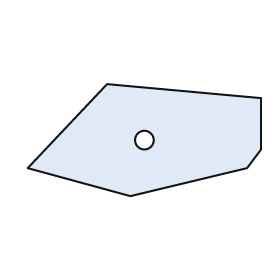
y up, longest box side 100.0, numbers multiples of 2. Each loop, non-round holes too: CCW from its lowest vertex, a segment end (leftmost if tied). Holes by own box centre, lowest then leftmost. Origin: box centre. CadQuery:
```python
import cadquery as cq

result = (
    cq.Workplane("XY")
    .moveTo(-6.0, -24.0)
    .lineTo(44.0, -12.0)
    .lineTo(50.0, -4.0)
    .lineTo(50.0, 18.0)
    .lineTo(-16.0, 24.0)
    .lineTo(-50.0, -12.0)
    .close()
    .moveTo(0.0, 0.0)
    .circle(4.0)
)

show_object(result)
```